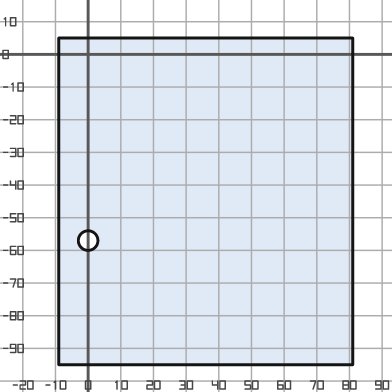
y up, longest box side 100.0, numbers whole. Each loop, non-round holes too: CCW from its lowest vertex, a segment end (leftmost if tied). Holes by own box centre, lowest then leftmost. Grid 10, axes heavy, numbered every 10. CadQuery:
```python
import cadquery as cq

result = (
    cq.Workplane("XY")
    .moveTo(-9.0, -95.0)
    .lineTo(81.0, -95.0)
    .lineTo(81.0, 5.0)
    .lineTo(-9.0, 5.0)
    .close()
    .moveTo(0.0, -57.0)
    .circle(3.0)
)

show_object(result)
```